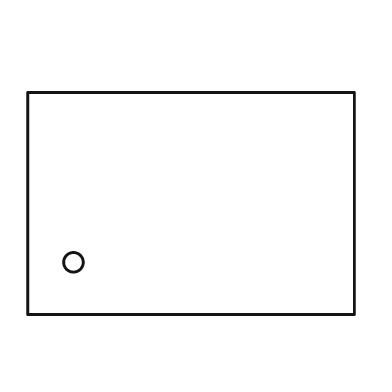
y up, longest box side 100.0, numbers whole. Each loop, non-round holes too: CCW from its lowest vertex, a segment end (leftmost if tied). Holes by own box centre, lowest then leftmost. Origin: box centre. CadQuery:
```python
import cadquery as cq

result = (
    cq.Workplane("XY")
    .moveTo(-50.0, -34.0)
    .lineTo(50.0, -34.0)
    .lineTo(50.0, 34.0)
    .lineTo(-50.0, 34.0)
    .close()
    .moveTo(-36.0, -18.0)
    .circle(3.0)
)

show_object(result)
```